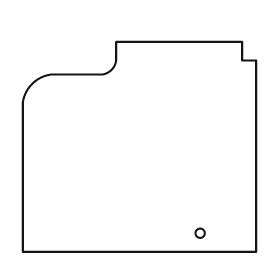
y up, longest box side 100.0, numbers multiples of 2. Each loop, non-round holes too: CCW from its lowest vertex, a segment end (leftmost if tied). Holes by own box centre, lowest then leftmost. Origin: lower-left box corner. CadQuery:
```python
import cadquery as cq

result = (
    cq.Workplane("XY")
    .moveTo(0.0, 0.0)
    .lineTo(100.0, 0.0)
    .lineTo(100.0, 82.0)
    .lineTo(94.0, 82.0)
    .lineTo(94.0, 90.0)
    .lineTo(40.0, 90.0)
    .lineTo(40.0, 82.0)
    .threePointArc((38.0, 78.0), (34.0, 76.0))
    .lineTo(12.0, 76.0)
    .threePointArc((4.0, 72.0), (0.0, 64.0))
    .close()
    .moveTo(76.0, 8.0)
    .circle(2.0)
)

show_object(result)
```